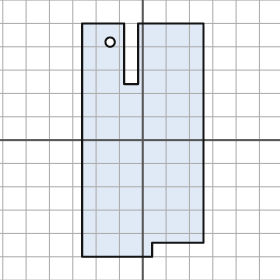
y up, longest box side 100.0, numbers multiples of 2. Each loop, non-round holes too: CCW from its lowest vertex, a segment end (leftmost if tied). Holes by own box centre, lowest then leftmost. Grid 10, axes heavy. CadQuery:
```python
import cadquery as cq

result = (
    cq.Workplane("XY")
    .moveTo(-26.0, -50.0)
    .lineTo(4.0, -50.0)
    .lineTo(4.0, -44.0)
    .lineTo(26.0, -44.0)
    .lineTo(26.0, 50.0)
    .lineTo(-2.0, 50.0)
    .lineTo(-2.0, 24.0)
    .lineTo(-8.0, 24.0)
    .lineTo(-8.0, 50.0)
    .lineTo(-26.0, 50.0)
    .close()
    .moveTo(-14.0, 42.0)
    .circle(2.0)
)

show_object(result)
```